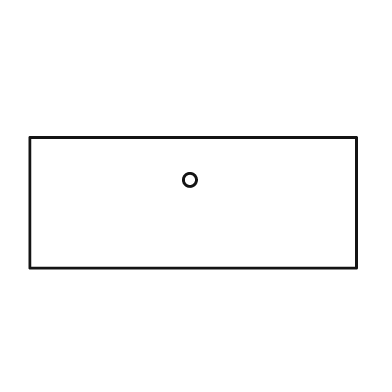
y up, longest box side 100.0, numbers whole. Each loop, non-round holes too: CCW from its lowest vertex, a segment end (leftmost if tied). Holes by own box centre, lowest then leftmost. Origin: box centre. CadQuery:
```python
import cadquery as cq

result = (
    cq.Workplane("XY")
    .moveTo(-50.0, -20.0)
    .lineTo(50.0, -20.0)
    .lineTo(50.0, 20.0)
    .lineTo(-50.0, 20.0)
    .close()
    .moveTo(-1.0, 7.0)
    .circle(2.0)
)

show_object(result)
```